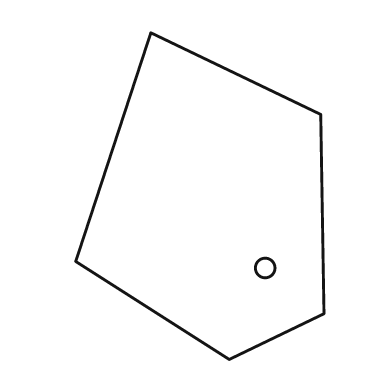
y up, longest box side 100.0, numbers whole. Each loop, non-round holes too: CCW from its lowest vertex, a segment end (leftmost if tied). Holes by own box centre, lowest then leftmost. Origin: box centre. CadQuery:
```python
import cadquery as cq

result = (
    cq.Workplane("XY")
    .moveTo(9.0, -50.0)
    .lineTo(38.0, -36.0)
    .lineTo(37.0, 25.0)
    .lineTo(-15.0, 50.0)
    .lineTo(-38.0, -20.0)
    .close()
    .moveTo(20.0, -22.0)
    .circle(3.0)
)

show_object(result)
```